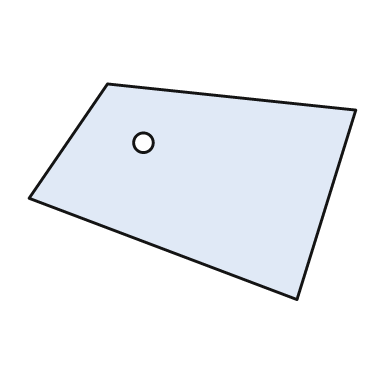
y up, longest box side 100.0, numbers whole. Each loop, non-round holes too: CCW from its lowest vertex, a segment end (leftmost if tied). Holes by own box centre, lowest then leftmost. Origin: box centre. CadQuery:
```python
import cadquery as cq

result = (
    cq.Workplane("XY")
    .moveTo(32.0, -33.0)
    .lineTo(50.0, 25.0)
    .lineTo(-26.0, 33.0)
    .lineTo(-50.0, -2.0)
    .close()
    .moveTo(-15.0, 15.0)
    .circle(3.0)
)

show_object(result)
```